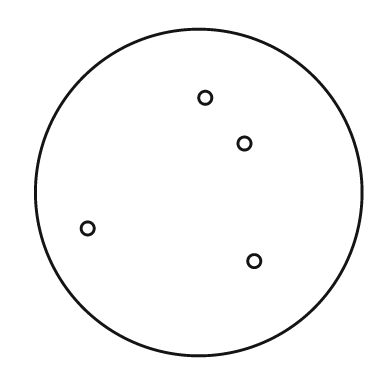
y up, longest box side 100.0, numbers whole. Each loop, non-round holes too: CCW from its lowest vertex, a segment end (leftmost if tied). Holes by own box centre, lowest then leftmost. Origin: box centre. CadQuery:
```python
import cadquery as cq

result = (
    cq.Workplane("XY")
    .moveTo(0.0, 0.0)
    .circle(50.0)
    .moveTo(17.0, -21.0)
    .circle(2.0)
    .moveTo(-34.0, -11.0)
    .circle(2.0)
    .moveTo(14.0, 15.0)
    .circle(2.0)
    .moveTo(2.0, 29.0)
    .circle(2.0)
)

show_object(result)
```